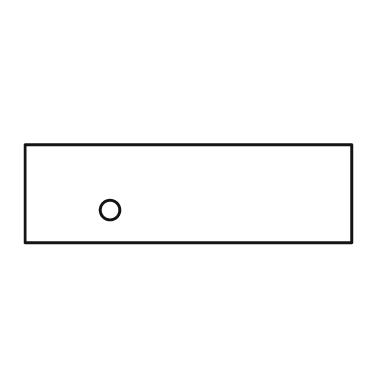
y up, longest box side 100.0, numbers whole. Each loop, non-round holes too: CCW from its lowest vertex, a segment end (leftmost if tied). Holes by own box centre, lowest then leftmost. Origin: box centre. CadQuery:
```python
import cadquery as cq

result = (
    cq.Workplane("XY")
    .moveTo(-50.0, -15.0)
    .lineTo(50.0, -15.0)
    .lineTo(50.0, 15.0)
    .lineTo(-50.0, 15.0)
    .close()
    .moveTo(-24.0, -5.0)
    .circle(3.0)
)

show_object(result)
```